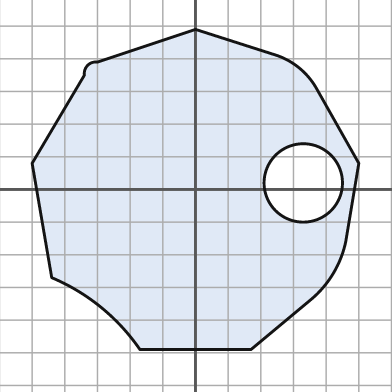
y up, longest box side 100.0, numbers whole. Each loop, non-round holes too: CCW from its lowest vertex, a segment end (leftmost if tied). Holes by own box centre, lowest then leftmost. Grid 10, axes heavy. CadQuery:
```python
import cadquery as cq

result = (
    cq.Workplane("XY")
    .moveTo(-17.0, -49.0)
    .lineTo(17.0, -49.0)
    .lineTo(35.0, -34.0)
    .threePointArc((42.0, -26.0), (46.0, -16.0))
    .lineTo(50.0, 8.0)
    .lineTo(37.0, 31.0)
    .threePointArc((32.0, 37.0), (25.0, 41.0))
    .lineTo(0.0, 49.0)
    .lineTo(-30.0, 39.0)
    .threePointArc((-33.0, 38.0), (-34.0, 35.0))
    .lineTo(-50.0, 8.0)
    .lineTo(-44.0, -27.0)
    .threePointArc((-29.0, -36.0), (-17.0, -49.0))
    .close()
    .moveTo(33.0, 2.0)
    .circle(12.0)
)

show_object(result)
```